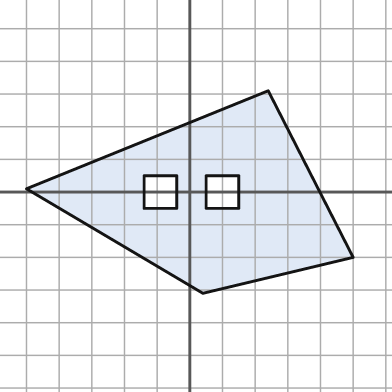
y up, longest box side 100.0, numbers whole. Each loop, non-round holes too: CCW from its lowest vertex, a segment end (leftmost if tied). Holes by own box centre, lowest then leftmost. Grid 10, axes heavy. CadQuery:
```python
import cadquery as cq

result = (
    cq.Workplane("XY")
    .moveTo(4.0, -31.0)
    .lineTo(50.0, -20.0)
    .lineTo(24.0, 31.0)
    .lineTo(-50.0, 1.0)
    .close()
    .moveTo(-14.0, -5.0)
    .lineTo(-4.0, -5.0)
    .lineTo(-4.0, 5.0)
    .lineTo(-14.0, 5.0)
    .close()
    .moveTo(5.0, -5.0)
    .lineTo(15.0, -5.0)
    .lineTo(15.0, 5.0)
    .lineTo(5.0, 5.0)
    .close()
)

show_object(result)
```